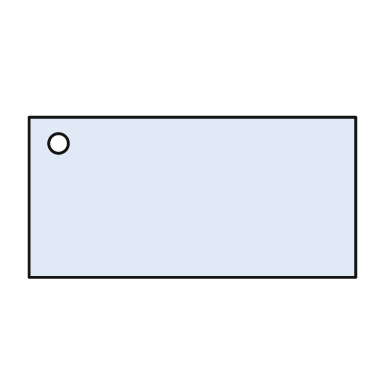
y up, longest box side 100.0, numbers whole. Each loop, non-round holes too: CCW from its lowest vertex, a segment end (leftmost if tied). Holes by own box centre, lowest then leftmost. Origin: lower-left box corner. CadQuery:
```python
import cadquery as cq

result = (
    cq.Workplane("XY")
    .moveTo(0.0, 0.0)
    .lineTo(100.0, 0.0)
    .lineTo(100.0, 49.0)
    .lineTo(0.0, 49.0)
    .close()
    .moveTo(9.0, 41.0)
    .circle(3.0)
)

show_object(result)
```